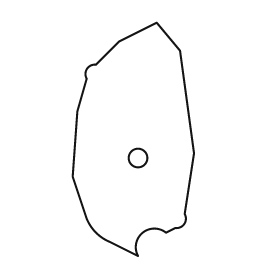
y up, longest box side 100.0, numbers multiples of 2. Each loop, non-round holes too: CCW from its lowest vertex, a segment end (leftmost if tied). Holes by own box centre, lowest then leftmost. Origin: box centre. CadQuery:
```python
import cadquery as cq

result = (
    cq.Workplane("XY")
    .moveTo(2.0, -50.0)
    .threePointArc((4.0, -40.0), (14.0, -40.0))
    .lineTo(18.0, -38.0)
    .threePointArc((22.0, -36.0), (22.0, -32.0))
    .lineTo(26.0, -6.0)
    .lineTo(20.0, 38.0)
    .lineTo(10.0, 50.0)
    .lineTo(-6.0, 42.0)
    .lineTo(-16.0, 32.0)
    .threePointArc((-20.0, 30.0), (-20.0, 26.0))
    .lineTo(-24.0, 12.0)
    .lineTo(-26.0, -16.0)
    .lineTo(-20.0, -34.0)
    .threePointArc((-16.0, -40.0), (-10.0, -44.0))
    .close()
    .moveTo(2.0, -8.0)
    .circle(4.0)
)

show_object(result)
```